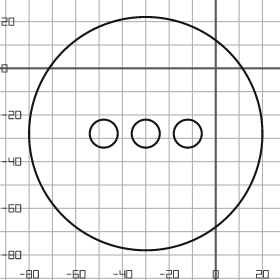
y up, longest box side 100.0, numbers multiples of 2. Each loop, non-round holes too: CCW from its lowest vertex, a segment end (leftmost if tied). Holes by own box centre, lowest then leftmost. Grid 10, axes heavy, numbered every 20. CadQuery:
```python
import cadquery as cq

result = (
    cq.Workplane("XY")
    .moveTo(-30.0, -28.0)
    .circle(50.0)
    .moveTo(-48.0, -28.0)
    .circle(6.0)
    .moveTo(-30.0, -28.0)
    .circle(6.0)
    .moveTo(-12.0, -28.0)
    .circle(6.0)
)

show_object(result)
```